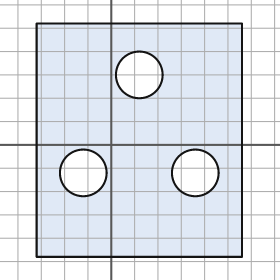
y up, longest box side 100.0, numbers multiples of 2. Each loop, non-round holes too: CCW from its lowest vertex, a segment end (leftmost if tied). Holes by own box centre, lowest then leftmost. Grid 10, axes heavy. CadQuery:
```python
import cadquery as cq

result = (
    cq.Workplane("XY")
    .moveTo(-32.0, -48.0)
    .lineTo(56.0, -48.0)
    .lineTo(56.0, 52.0)
    .lineTo(-32.0, 52.0)
    .close()
    .moveTo(-12.0, -12.0)
    .circle(10.0)
    .moveTo(36.0, -12.0)
    .circle(10.0)
    .moveTo(12.0, 30.0)
    .circle(10.0)
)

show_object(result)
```